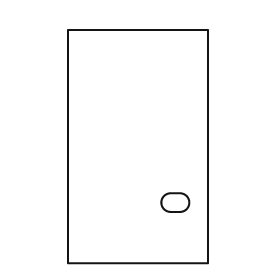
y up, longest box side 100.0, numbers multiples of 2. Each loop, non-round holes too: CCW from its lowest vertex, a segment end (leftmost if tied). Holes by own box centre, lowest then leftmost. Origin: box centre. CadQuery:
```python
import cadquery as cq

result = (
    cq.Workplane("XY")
    .moveTo(-30.0, -50.0)
    .lineTo(30.0, -50.0)
    .lineTo(30.0, 50.0)
    .lineTo(-30.0, 50.0)
    .close()
    .moveTo(14.0, -28.0)
    .lineTo(18.0, -28.0)
    .threePointArc((22.0, -24.0), (18.0, -20.0))
    .lineTo(14.0, -20.0)
    .threePointArc((10.0, -24.0), (14.0, -28.0))
    .close()
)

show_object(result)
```